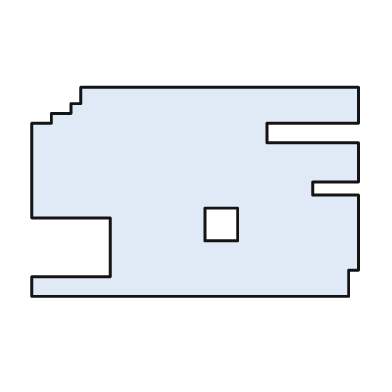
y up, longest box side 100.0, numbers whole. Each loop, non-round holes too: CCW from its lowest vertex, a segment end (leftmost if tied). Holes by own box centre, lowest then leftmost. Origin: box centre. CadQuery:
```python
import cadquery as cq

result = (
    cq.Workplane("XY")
    .moveTo(-50.0, -32.0)
    .lineTo(47.0, -32.0)
    .lineTo(47.0, -24.0)
    .lineTo(50.0, -24.0)
    .lineTo(50.0, -1.0)
    .lineTo(36.0, -1.0)
    .lineTo(36.0, 3.0)
    .lineTo(50.0, 3.0)
    .lineTo(50.0, 15.0)
    .lineTo(22.0, 15.0)
    .lineTo(22.0, 21.0)
    .lineTo(50.0, 21.0)
    .lineTo(50.0, 32.0)
    .lineTo(-35.0, 32.0)
    .lineTo(-35.0, 27.0)
    .lineTo(-38.0, 27.0)
    .lineTo(-38.0, 24.0)
    .lineTo(-44.0, 24.0)
    .lineTo(-44.0, 21.0)
    .lineTo(-50.0, 21.0)
    .lineTo(-50.0, -8.0)
    .lineTo(-26.0, -8.0)
    .lineTo(-26.0, -26.0)
    .lineTo(-50.0, -26.0)
    .close()
    .moveTo(3.0, -15.0)
    .lineTo(13.0, -15.0)
    .lineTo(13.0, -5.0)
    .lineTo(3.0, -5.0)
    .close()
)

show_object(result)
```